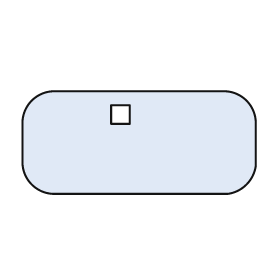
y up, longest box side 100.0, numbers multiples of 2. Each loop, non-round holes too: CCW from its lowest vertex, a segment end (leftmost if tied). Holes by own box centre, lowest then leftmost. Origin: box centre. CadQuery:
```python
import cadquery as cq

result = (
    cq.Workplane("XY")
    .moveTo(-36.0, -22.0)
    .lineTo(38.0, -22.0)
    .threePointArc((46.0, -18.0), (50.0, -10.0))
    .lineTo(50.0, 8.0)
    .threePointArc((46.0, 18.0), (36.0, 22.0))
    .lineTo(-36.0, 22.0)
    .threePointArc((-46.0, 18.0), (-50.0, 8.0))
    .lineTo(-50.0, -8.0)
    .threePointArc((-46.0, -18.0), (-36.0, -22.0))
    .close()
    .moveTo(-12.0, 8.0)
    .lineTo(-4.0, 8.0)
    .lineTo(-4.0, 16.0)
    .lineTo(-12.0, 16.0)
    .close()
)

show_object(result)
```